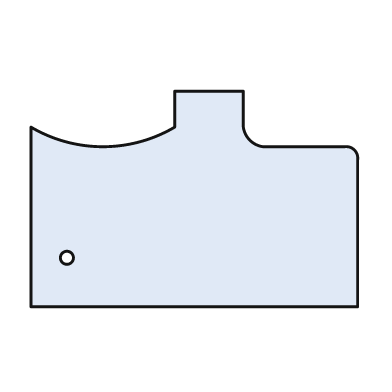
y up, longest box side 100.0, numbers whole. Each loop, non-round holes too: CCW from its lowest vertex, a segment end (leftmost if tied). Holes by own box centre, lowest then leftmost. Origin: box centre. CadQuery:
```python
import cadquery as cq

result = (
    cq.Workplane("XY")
    .moveTo(-50.0, -33.0)
    .lineTo(50.0, -33.0)
    .lineTo(50.0, 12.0)
    .threePointArc((49.0, 15.0), (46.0, 16.0))
    .lineTo(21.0, 16.0)
    .threePointArc((17.0, 18.0), (15.0, 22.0))
    .lineTo(15.0, 33.0)
    .lineTo(-6.0, 33.0)
    .lineTo(-6.0, 22.0)
    .threePointArc((-28.0, 16.0), (-50.0, 22.0))
    .close()
    .moveTo(-39.0, -18.0)
    .circle(2.0)
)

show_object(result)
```